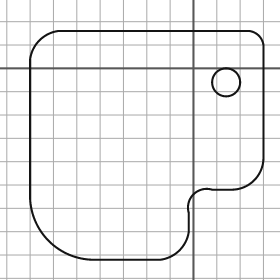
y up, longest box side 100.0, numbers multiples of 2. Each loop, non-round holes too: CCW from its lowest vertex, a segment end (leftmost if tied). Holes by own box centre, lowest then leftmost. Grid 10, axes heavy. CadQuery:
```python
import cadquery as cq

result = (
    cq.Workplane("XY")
    .moveTo(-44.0, -82.0)
    .lineTo(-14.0, -82.0)
    .threePointArc((-6.0, -78.0), (-2.0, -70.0))
    .lineTo(-2.0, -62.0)
    .threePointArc((0.0, -54.0), (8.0, -52.0))
    .lineTo(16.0, -52.0)
    .threePointArc((26.0, -48.0), (30.0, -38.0))
    .lineTo(30.0, 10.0)
    .threePointArc((28.0, 14.0), (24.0, 16.0))
    .lineTo(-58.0, 16.0)
    .threePointArc((-66.0, 12.0), (-70.0, 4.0))
    .lineTo(-70.0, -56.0)
    .threePointArc((-62.0, -74.0), (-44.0, -82.0))
    .close()
    .moveTo(14.0, -6.0)
    .circle(6.0)
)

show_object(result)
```